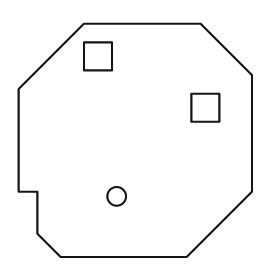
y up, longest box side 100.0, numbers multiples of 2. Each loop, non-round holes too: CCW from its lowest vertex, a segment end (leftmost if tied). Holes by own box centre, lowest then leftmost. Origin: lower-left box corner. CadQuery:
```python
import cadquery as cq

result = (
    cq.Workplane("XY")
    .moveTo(18.0, 0.0)
    .lineTo(72.0, 0.0)
    .lineTo(100.0, 28.0)
    .lineTo(100.0, 78.0)
    .lineTo(78.0, 100.0)
    .lineTo(28.0, 100.0)
    .lineTo(0.0, 72.0)
    .lineTo(0.0, 28.0)
    .lineTo(8.0, 28.0)
    .lineTo(8.0, 10.0)
    .close()
    .moveTo(42.0, 26.0)
    .circle(4.0)
    .moveTo(74.0, 58.0)
    .lineTo(86.0, 58.0)
    .lineTo(86.0, 70.0)
    .lineTo(74.0, 70.0)
    .close()
    .moveTo(28.0, 80.0)
    .lineTo(40.0, 80.0)
    .lineTo(40.0, 92.0)
    .lineTo(28.0, 92.0)
    .close()
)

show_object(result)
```